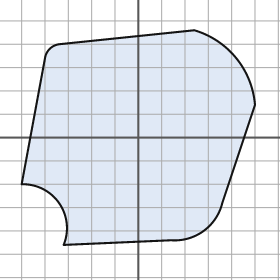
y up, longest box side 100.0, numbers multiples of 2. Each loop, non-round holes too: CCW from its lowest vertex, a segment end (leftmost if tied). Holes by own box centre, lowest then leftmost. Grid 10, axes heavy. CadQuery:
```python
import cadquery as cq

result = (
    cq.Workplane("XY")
    .moveTo(-32.0, -46.0)
    .lineTo(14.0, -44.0)
    .threePointArc((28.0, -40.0), (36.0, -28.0))
    .lineTo(50.0, 14.0)
    .threePointArc((42.0, 34.0), (24.0, 46.0))
    .lineTo(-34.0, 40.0)
    .threePointArc((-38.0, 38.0), (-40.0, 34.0))
    .lineTo(-50.0, -20.0)
    .threePointArc((-34.0, -28.0), (-32.0, -46.0))
    .close()
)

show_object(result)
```